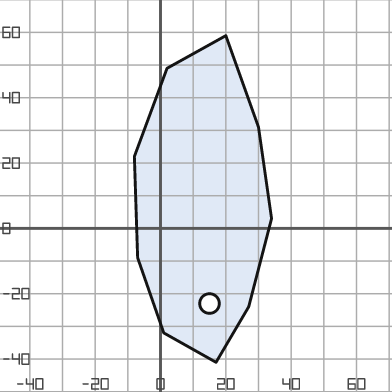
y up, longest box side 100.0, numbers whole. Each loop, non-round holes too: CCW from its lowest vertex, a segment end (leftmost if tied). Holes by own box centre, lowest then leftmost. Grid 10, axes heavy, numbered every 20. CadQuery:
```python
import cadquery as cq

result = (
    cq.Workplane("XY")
    .moveTo(17.0, -41.0)
    .lineTo(27.0, -24.0)
    .lineTo(34.0, 3.0)
    .lineTo(30.0, 31.0)
    .lineTo(20.0, 59.0)
    .lineTo(2.0, 49.0)
    .lineTo(-8.0, 22.0)
    .lineTo(-7.0, -9.0)
    .lineTo(1.0, -32.0)
    .close()
    .moveTo(15.0, -23.0)
    .circle(3.0)
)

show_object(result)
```